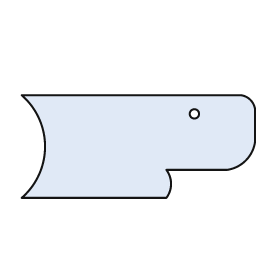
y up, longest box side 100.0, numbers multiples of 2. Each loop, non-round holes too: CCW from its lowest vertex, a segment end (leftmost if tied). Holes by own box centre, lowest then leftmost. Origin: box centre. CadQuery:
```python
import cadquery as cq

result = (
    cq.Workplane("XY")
    .moveTo(-50.0, -22.0)
    .lineTo(12.0, -22.0)
    .threePointArc((14.0, -16.0), (12.0, -10.0))
    .lineTo(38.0, -10.0)
    .threePointArc((46.0, -6.0), (50.0, 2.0))
    .lineTo(50.0, 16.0)
    .threePointArc((48.0, 20.0), (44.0, 22.0))
    .lineTo(-50.0, 22.0)
    .threePointArc((-40.0, 0.0), (-50.0, -22.0))
    .close()
    .moveTo(24.0, 14.0)
    .circle(2.0)
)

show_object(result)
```